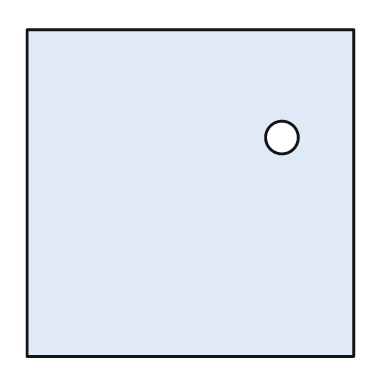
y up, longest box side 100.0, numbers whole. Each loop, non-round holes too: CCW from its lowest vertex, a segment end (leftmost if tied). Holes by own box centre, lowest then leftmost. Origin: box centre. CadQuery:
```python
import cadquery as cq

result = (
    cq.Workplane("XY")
    .moveTo(-50.0, -50.0)
    .lineTo(50.0, -50.0)
    .lineTo(50.0, 50.0)
    .lineTo(-50.0, 50.0)
    .close()
    .moveTo(28.0, 17.0)
    .circle(5.0)
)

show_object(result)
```